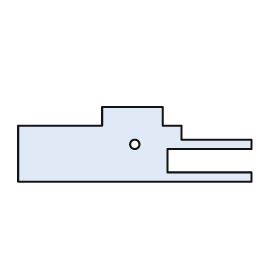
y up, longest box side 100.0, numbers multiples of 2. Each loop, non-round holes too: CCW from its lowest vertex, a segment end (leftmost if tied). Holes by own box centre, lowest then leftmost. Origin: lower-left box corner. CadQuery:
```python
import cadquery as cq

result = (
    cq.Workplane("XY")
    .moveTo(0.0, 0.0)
    .lineTo(100.0, 0.0)
    .lineTo(100.0, 4.0)
    .lineTo(64.0, 4.0)
    .lineTo(64.0, 14.0)
    .lineTo(100.0, 14.0)
    .lineTo(100.0, 18.0)
    .lineTo(70.0, 18.0)
    .lineTo(70.0, 24.0)
    .lineTo(62.0, 24.0)
    .lineTo(62.0, 32.0)
    .lineTo(36.0, 32.0)
    .lineTo(36.0, 24.0)
    .lineTo(0.0, 24.0)
    .close()
    .moveTo(50.0, 16.0)
    .circle(2.0)
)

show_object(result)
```